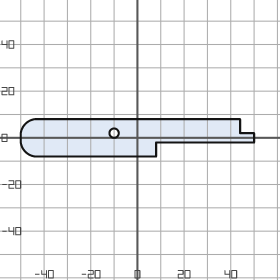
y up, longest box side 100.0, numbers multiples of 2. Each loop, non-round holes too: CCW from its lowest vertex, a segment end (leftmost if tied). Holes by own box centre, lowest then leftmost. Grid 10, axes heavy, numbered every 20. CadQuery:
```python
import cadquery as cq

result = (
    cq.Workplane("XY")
    .moveTo(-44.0, -8.0)
    .lineTo(8.0, -8.0)
    .lineTo(8.0, -2.0)
    .lineTo(50.0, -2.0)
    .lineTo(50.0, 2.0)
    .lineTo(44.0, 2.0)
    .lineTo(44.0, 8.0)
    .lineTo(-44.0, 8.0)
    .threePointArc((-48.0, 6.0), (-50.0, 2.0))
    .lineTo(-50.0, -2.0)
    .threePointArc((-48.0, -6.0), (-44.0, -8.0))
    .close()
    .moveTo(-10.0, 2.0)
    .circle(2.0)
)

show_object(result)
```